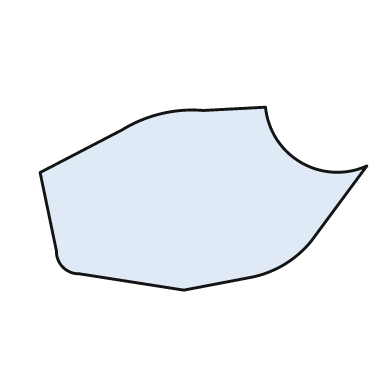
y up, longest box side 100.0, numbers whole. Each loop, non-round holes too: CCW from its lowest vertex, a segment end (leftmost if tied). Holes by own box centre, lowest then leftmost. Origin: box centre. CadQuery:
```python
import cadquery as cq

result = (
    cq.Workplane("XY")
    .moveTo(-6.0, -28.0)
    .lineTo(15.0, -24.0)
    .threePointArc((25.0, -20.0), (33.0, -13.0))
    .lineTo(50.0, 10.0)
    .threePointArc((30.0, 11.0), (19.0, 28.0))
    .lineTo(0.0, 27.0)
    .threePointArc((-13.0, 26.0), (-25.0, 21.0))
    .lineTo(-50.0, 8.0)
    .lineTo(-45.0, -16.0)
    .threePointArc((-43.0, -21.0), (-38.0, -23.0))
    .close()
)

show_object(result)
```